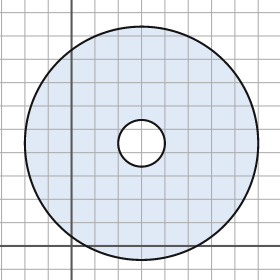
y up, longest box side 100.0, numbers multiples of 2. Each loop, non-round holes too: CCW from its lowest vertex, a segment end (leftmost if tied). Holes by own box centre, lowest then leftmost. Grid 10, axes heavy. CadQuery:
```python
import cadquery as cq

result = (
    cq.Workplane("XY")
    .moveTo(30.0, 44.0)
    .circle(50.0)
    .moveTo(30.0, 44.0)
    .circle(10.0)
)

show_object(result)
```